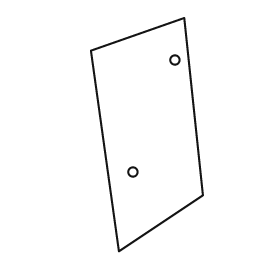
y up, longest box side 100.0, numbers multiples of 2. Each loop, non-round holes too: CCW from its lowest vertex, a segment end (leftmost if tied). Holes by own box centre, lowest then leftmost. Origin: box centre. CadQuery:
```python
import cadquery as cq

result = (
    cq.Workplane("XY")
    .moveTo(-12.0, -50.0)
    .lineTo(24.0, -26.0)
    .lineTo(16.0, 50.0)
    .lineTo(-24.0, 36.0)
    .close()
    .moveTo(-6.0, -16.0)
    .circle(2.0)
    .moveTo(12.0, 32.0)
    .circle(2.0)
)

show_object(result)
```